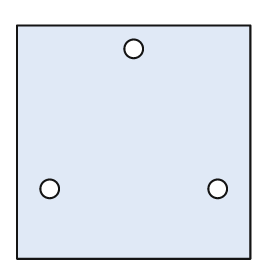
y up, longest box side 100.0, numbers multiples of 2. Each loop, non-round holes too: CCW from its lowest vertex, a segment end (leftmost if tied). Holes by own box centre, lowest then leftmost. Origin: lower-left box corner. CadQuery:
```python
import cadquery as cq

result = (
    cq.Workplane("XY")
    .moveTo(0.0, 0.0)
    .lineTo(100.0, 0.0)
    .lineTo(100.0, 100.0)
    .lineTo(0.0, 100.0)
    .close()
    .moveTo(14.0, 30.0)
    .circle(4.0)
    .moveTo(86.0, 30.0)
    .circle(4.0)
    .moveTo(50.0, 90.0)
    .circle(4.0)
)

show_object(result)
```